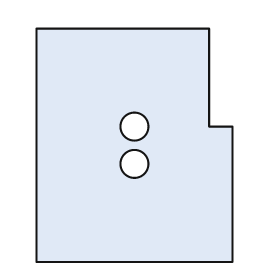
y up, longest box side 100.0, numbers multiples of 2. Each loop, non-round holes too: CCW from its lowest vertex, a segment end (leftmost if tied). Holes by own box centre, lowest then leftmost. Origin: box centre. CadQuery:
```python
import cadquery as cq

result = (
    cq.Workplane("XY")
    .moveTo(-42.0, -50.0)
    .lineTo(42.0, -50.0)
    .lineTo(42.0, 8.0)
    .lineTo(32.0, 8.0)
    .lineTo(32.0, 50.0)
    .lineTo(-42.0, 50.0)
    .close()
    .moveTo(0.0, -8.0)
    .circle(6.0)
    .moveTo(0.0, 8.0)
    .circle(6.0)
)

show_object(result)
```